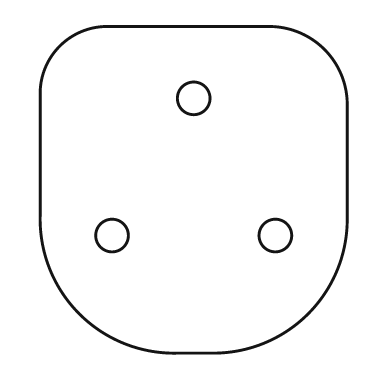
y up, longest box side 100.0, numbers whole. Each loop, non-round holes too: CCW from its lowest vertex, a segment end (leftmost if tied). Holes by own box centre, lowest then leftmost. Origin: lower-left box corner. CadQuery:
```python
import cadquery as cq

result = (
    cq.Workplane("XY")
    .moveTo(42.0, 0.0)
    .lineTo(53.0, 0.0)
    .threePointArc((82.0, 12.0), (94.0, 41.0))
    .lineTo(94.0, 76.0)
    .threePointArc((87.0, 93.0), (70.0, 100.0))
    .lineTo(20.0, 100.0)
    .threePointArc((6.0, 94.0), (0.0, 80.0))
    .lineTo(0.0, 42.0)
    .threePointArc((12.0, 12.0), (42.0, 0.0))
    .close()
    .moveTo(22.0, 36.0)
    .circle(5.0)
    .moveTo(72.0, 36.0)
    .circle(5.0)
    .moveTo(47.0, 78.0)
    .circle(5.0)
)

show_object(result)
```